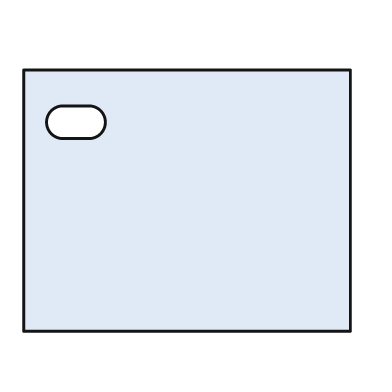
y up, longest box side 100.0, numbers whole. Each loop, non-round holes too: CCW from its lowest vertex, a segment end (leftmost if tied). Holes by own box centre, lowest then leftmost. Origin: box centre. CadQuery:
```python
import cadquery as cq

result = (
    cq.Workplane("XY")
    .moveTo(-50.0, -40.0)
    .lineTo(50.0, -40.0)
    .lineTo(50.0, 40.0)
    .lineTo(-50.0, 40.0)
    .close()
    .moveTo(-38.0, 19.0)
    .lineTo(-30.0, 19.0)
    .threePointArc((-25.0, 24.0), (-30.0, 29.0))
    .lineTo(-38.0, 29.0)
    .threePointArc((-43.0, 24.0), (-38.0, 19.0))
    .close()
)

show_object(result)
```